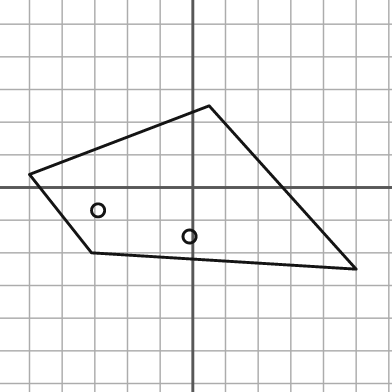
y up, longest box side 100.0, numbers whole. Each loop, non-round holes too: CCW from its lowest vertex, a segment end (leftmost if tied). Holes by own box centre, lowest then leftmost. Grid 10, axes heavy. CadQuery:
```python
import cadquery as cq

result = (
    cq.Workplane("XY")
    .moveTo(50.0, -25.0)
    .lineTo(5.0, 25.0)
    .lineTo(-50.0, 4.0)
    .lineTo(-31.0, -20.0)
    .close()
    .moveTo(-1.0, -15.0)
    .circle(2.0)
    .moveTo(-29.0, -7.0)
    .circle(2.0)
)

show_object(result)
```